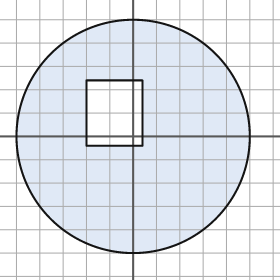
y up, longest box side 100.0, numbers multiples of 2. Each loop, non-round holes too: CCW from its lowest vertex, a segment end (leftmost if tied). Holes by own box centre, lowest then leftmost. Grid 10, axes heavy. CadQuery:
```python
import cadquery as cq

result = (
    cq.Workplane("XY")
    .moveTo(0.0, 0.0)
    .circle(50.0)
    .moveTo(-20.0, -4.0)
    .lineTo(4.0, -4.0)
    .lineTo(4.0, 24.0)
    .lineTo(-20.0, 24.0)
    .close()
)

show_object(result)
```